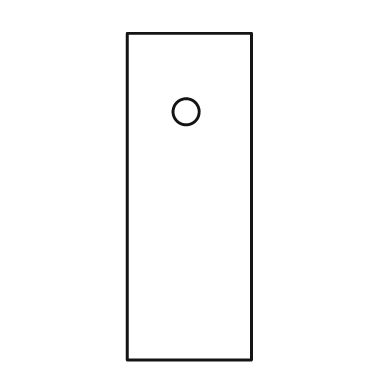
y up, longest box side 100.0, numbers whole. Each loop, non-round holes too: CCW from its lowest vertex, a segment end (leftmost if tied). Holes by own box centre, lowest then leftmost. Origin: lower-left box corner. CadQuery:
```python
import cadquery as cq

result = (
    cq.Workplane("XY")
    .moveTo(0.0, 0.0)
    .lineTo(38.0, 0.0)
    .lineTo(38.0, 100.0)
    .lineTo(0.0, 100.0)
    .close()
    .moveTo(18.0, 76.0)
    .circle(4.0)
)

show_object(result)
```